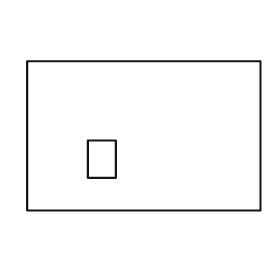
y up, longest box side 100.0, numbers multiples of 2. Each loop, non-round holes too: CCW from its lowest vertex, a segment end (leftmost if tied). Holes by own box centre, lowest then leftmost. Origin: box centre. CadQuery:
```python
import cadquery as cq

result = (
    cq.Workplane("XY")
    .moveTo(-50.0, -32.0)
    .lineTo(50.0, -32.0)
    .lineTo(50.0, 32.0)
    .lineTo(-50.0, 32.0)
    .close()
    .moveTo(-24.0, -18.0)
    .lineTo(-12.0, -18.0)
    .lineTo(-12.0, -2.0)
    .lineTo(-24.0, -2.0)
    .close()
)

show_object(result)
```